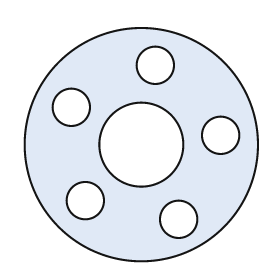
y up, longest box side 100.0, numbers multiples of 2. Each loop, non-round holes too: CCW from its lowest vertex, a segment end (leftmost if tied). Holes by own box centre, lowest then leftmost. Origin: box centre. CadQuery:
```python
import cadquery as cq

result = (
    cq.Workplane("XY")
    .moveTo(0.0, 0.0)
    .circle(50.0)
    .moveTo(16.0, -32.0)
    .circle(8.0)
    .moveTo(-24.0, -24.0)
    .circle(8.0)
    .moveTo(0.0, 0.0)
    .circle(18.0)
    .moveTo(34.0, 4.0)
    .circle(8.0)
    .moveTo(-30.0, 16.0)
    .circle(8.0)
    .moveTo(6.0, 34.0)
    .circle(8.0)
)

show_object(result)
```